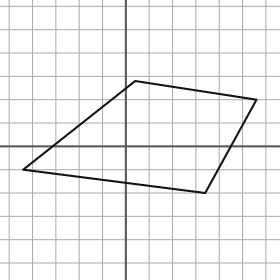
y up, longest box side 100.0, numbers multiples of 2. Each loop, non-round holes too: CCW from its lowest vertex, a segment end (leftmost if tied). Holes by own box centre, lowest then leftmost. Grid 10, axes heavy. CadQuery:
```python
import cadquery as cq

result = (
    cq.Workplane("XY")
    .moveTo(34.0, -20.0)
    .lineTo(56.0, 20.0)
    .lineTo(4.0, 28.0)
    .lineTo(-44.0, -10.0)
    .close()
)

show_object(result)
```